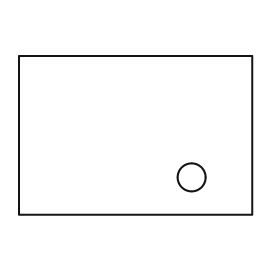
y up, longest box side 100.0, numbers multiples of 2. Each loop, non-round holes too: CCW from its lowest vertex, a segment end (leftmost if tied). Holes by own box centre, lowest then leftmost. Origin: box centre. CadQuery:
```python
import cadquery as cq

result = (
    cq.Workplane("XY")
    .moveTo(-50.0, -34.0)
    .lineTo(50.0, -34.0)
    .lineTo(50.0, 34.0)
    .lineTo(-50.0, 34.0)
    .close()
    .moveTo(24.0, -18.0)
    .circle(6.0)
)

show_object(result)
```